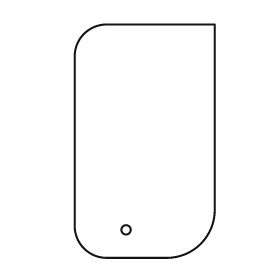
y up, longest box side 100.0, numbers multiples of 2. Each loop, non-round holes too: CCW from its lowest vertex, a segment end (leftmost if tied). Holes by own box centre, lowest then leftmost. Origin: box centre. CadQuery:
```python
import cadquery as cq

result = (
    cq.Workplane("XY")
    .moveTo(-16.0, -50.0)
    .lineTo(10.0, -50.0)
    .threePointArc((24.0, -44.0), (30.0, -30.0))
    .lineTo(30.0, 50.0)
    .lineTo(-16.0, 50.0)
    .threePointArc((-26.0, 46.0), (-30.0, 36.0))
    .lineTo(-30.0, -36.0)
    .threePointArc((-26.0, -46.0), (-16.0, -50.0))
    .close()
    .moveTo(-8.0, -38.0)
    .circle(2.0)
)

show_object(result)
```